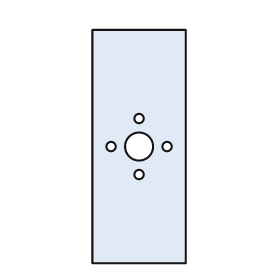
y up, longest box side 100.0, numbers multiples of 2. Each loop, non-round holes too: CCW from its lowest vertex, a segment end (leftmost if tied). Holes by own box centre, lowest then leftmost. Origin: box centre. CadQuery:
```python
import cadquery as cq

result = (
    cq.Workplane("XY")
    .moveTo(-20.0, -50.0)
    .lineTo(20.0, -50.0)
    .lineTo(20.0, 50.0)
    .lineTo(-20.0, 50.0)
    .close()
    .moveTo(0.0, -12.0)
    .circle(2.0)
    .moveTo(-12.0, 0.0)
    .circle(2.0)
    .moveTo(0.0, 0.0)
    .circle(6.0)
    .moveTo(12.0, 0.0)
    .circle(2.0)
    .moveTo(0.0, 12.0)
    .circle(2.0)
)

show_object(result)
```